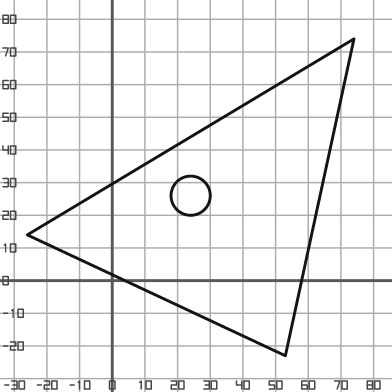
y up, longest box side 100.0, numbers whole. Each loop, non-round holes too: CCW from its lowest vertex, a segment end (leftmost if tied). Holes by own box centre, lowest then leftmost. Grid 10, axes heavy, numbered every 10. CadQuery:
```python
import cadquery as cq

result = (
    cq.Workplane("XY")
    .moveTo(53.0, -23.0)
    .lineTo(74.0, 74.0)
    .lineTo(-26.0, 14.0)
    .close()
    .moveTo(24.0, 26.0)
    .circle(6.0)
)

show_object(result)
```